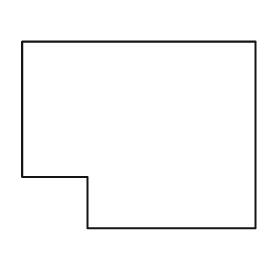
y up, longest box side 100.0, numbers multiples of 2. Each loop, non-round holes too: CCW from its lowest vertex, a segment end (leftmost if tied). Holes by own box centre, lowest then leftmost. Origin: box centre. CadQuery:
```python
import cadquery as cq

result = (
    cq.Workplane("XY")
    .moveTo(-22.0, -40.0)
    .lineTo(50.0, -40.0)
    .lineTo(50.0, 40.0)
    .lineTo(-50.0, 40.0)
    .lineTo(-50.0, -18.0)
    .lineTo(-22.0, -18.0)
    .close()
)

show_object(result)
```